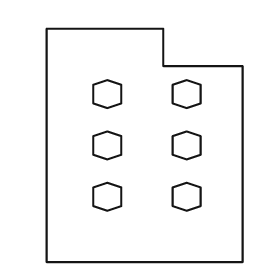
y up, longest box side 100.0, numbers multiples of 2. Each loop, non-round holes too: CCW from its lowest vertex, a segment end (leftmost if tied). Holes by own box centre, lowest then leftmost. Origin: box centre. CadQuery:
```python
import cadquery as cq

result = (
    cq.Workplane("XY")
    .moveTo(-42.0, -50.0)
    .lineTo(42.0, -50.0)
    .lineTo(42.0, 34.0)
    .lineTo(8.0, 34.0)
    .lineTo(8.0, 50.0)
    .lineTo(-42.0, 50.0)
    .close()
    .moveTo(-16.0, -28.0)
    .lineTo(-10.0, -26.0)
    .lineTo(-10.0, -18.0)
    .lineTo(-16.0, -16.0)
    .lineTo(-22.0, -18.0)
    .lineTo(-22.0, -26.0)
    .close()
    .moveTo(18.0, -28.0)
    .lineTo(24.0, -26.0)
    .lineTo(24.0, -18.0)
    .lineTo(18.0, -16.0)
    .lineTo(12.0, -18.0)
    .lineTo(12.0, -26.0)
    .close()
    .moveTo(-16.0, -6.0)
    .lineTo(-10.0, -4.0)
    .lineTo(-10.0, 4.0)
    .lineTo(-16.0, 6.0)
    .lineTo(-22.0, 4.0)
    .lineTo(-22.0, -4.0)
    .close()
    .moveTo(18.0, -6.0)
    .lineTo(24.0, -4.0)
    .lineTo(24.0, 4.0)
    .lineTo(18.0, 6.0)
    .lineTo(12.0, 4.0)
    .lineTo(12.0, -4.0)
    .close()
    .moveTo(-16.0, 16.0)
    .lineTo(-10.0, 18.0)
    .lineTo(-10.0, 26.0)
    .lineTo(-16.0, 28.0)
    .lineTo(-22.0, 26.0)
    .lineTo(-22.0, 18.0)
    .close()
    .moveTo(18.0, 16.0)
    .lineTo(24.0, 18.0)
    .lineTo(24.0, 26.0)
    .lineTo(18.0, 28.0)
    .lineTo(12.0, 26.0)
    .lineTo(12.0, 18.0)
    .close()
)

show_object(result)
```